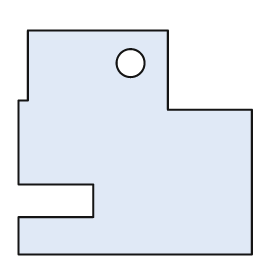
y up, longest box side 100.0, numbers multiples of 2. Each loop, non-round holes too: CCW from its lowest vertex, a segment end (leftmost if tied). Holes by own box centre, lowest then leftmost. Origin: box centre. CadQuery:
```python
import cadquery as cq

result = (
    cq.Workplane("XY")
    .moveTo(-50.0, -48.0)
    .lineTo(50.0, -48.0)
    .lineTo(50.0, 14.0)
    .lineTo(14.0, 14.0)
    .lineTo(14.0, 48.0)
    .lineTo(-46.0, 48.0)
    .lineTo(-46.0, 18.0)
    .lineTo(-50.0, 18.0)
    .lineTo(-50.0, -18.0)
    .lineTo(-18.0, -18.0)
    .lineTo(-18.0, -32.0)
    .lineTo(-50.0, -32.0)
    .close()
    .moveTo(-2.0, 34.0)
    .circle(6.0)
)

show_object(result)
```